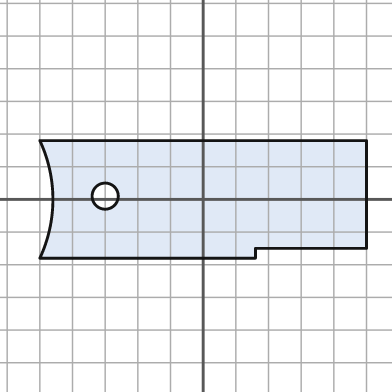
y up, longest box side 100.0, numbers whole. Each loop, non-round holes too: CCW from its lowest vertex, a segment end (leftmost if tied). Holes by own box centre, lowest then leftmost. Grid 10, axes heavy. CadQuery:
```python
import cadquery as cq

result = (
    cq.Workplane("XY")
    .moveTo(-50.0, -18.0)
    .lineTo(16.0, -18.0)
    .lineTo(16.0, -15.0)
    .lineTo(50.0, -15.0)
    .lineTo(50.0, 18.0)
    .lineTo(-50.0, 18.0)
    .threePointArc((-46.0, 0.0), (-50.0, -18.0))
    .close()
    .moveTo(-30.0, 1.0)
    .circle(4.0)
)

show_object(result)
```